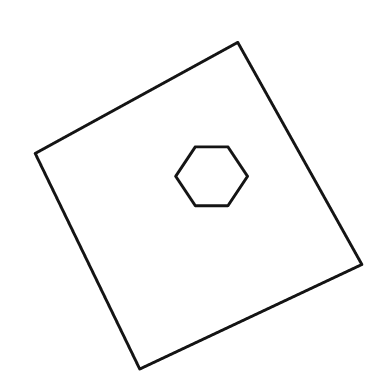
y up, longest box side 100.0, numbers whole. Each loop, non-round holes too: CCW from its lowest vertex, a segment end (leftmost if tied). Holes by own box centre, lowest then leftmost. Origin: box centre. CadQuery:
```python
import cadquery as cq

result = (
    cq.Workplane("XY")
    .moveTo(-18.0, -50.0)
    .lineTo(50.0, -18.0)
    .lineTo(12.0, 50.0)
    .lineTo(-50.0, 16.0)
    .close()
    .moveTo(-1.0, 0.0)
    .lineTo(9.0, 0.0)
    .lineTo(15.0, 9.0)
    .lineTo(9.0, 18.0)
    .lineTo(-1.0, 18.0)
    .lineTo(-7.0, 9.0)
    .close()
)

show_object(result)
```